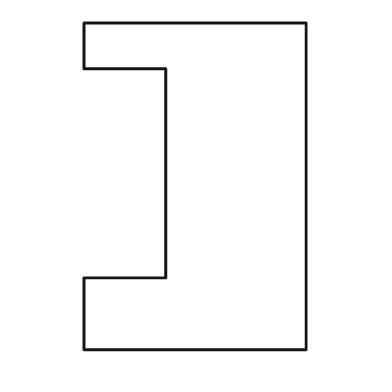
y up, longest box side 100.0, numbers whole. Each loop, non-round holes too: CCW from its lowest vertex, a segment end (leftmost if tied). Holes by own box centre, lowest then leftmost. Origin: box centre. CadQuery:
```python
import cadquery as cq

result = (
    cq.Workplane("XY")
    .moveTo(-34.0, -50.0)
    .lineTo(34.0, -50.0)
    .lineTo(34.0, 50.0)
    .lineTo(-34.0, 50.0)
    .lineTo(-34.0, 36.0)
    .lineTo(-9.0, 36.0)
    .lineTo(-9.0, -28.0)
    .lineTo(-34.0, -28.0)
    .close()
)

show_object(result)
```